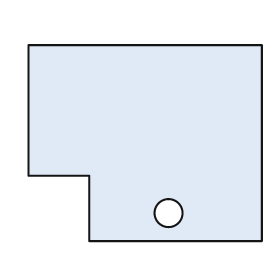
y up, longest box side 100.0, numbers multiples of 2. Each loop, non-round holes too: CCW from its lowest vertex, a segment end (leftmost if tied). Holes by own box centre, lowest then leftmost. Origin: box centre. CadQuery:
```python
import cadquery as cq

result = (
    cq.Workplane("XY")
    .moveTo(-24.0, -42.0)
    .lineTo(50.0, -42.0)
    .lineTo(50.0, 42.0)
    .lineTo(-50.0, 42.0)
    .lineTo(-50.0, -14.0)
    .lineTo(-24.0, -14.0)
    .close()
    .moveTo(10.0, -30.0)
    .circle(6.0)
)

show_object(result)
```